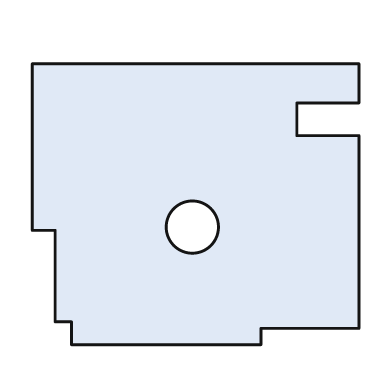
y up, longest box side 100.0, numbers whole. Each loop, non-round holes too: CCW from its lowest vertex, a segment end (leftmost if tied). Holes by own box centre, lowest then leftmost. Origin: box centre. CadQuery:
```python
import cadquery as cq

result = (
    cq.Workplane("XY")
    .moveTo(-38.0, -43.0)
    .lineTo(20.0, -43.0)
    .lineTo(20.0, -38.0)
    .lineTo(50.0, -38.0)
    .lineTo(50.0, 21.0)
    .lineTo(31.0, 21.0)
    .lineTo(31.0, 31.0)
    .lineTo(50.0, 31.0)
    .lineTo(50.0, 43.0)
    .lineTo(-50.0, 43.0)
    .lineTo(-50.0, -8.0)
    .lineTo(-43.0, -8.0)
    .lineTo(-43.0, -36.0)
    .lineTo(-38.0, -36.0)
    .close()
    .moveTo(-1.0, -7.0)
    .circle(8.0)
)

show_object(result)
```